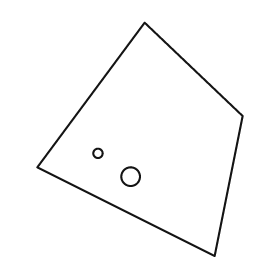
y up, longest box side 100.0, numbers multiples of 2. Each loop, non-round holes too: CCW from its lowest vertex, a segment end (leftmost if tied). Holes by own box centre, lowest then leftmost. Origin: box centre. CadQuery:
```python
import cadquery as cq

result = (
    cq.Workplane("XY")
    .moveTo(32.0, -50.0)
    .lineTo(44.0, 10.0)
    .lineTo(2.0, 50.0)
    .lineTo(-44.0, -12.0)
    .close()
    .moveTo(-4.0, -16.0)
    .circle(4.0)
    .moveTo(-18.0, -6.0)
    .circle(2.0)
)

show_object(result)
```